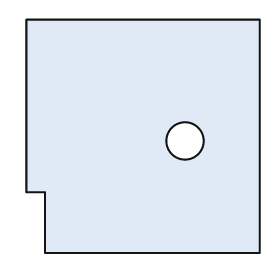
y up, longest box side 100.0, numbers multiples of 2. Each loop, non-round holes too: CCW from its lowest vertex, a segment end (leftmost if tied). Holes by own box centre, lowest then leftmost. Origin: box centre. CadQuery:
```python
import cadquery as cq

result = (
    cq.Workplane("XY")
    .moveTo(-42.0, -50.0)
    .lineTo(50.0, -50.0)
    .lineTo(50.0, 50.0)
    .lineTo(-50.0, 50.0)
    .lineTo(-50.0, -24.0)
    .lineTo(-42.0, -24.0)
    .close()
    .moveTo(18.0, -2.0)
    .circle(8.0)
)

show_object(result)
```